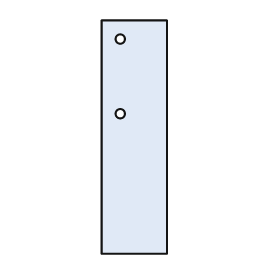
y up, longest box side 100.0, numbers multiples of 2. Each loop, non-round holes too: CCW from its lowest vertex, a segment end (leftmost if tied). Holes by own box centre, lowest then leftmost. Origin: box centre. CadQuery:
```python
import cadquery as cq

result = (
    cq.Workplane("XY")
    .moveTo(-14.0, -50.0)
    .lineTo(14.0, -50.0)
    .lineTo(14.0, 50.0)
    .lineTo(-14.0, 50.0)
    .close()
    .moveTo(-6.0, 10.0)
    .circle(2.0)
    .moveTo(-6.0, 42.0)
    .circle(2.0)
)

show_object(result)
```